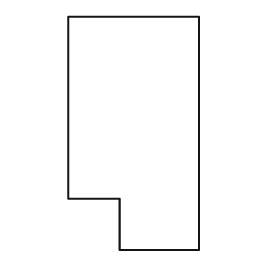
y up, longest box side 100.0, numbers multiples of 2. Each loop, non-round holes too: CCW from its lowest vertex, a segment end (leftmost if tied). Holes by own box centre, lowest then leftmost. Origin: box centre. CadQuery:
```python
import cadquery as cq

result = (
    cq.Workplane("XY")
    .moveTo(-6.0, -50.0)
    .lineTo(28.0, -50.0)
    .lineTo(28.0, 50.0)
    .lineTo(-28.0, 50.0)
    .lineTo(-28.0, -28.0)
    .lineTo(-6.0, -28.0)
    .close()
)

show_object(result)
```